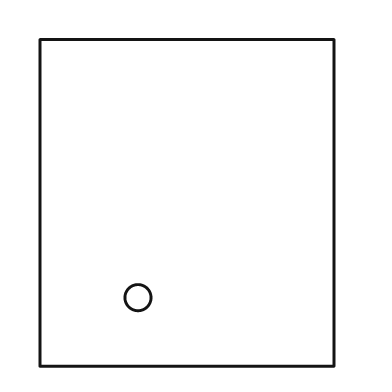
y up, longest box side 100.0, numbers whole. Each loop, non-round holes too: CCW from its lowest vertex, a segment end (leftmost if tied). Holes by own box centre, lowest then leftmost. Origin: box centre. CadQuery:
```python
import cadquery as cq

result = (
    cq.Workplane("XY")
    .moveTo(-45.0, -50.0)
    .lineTo(45.0, -50.0)
    .lineTo(45.0, 50.0)
    .lineTo(-45.0, 50.0)
    .close()
    .moveTo(-15.0, -29.0)
    .circle(4.0)
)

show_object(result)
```